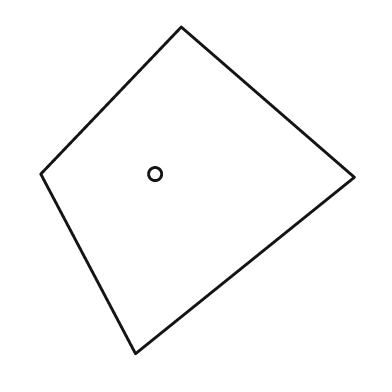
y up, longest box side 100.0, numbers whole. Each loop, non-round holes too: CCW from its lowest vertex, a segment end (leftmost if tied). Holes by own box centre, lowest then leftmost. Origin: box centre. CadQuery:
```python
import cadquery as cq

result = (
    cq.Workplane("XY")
    .moveTo(-19.0, -50.0)
    .lineTo(48.0, 4.0)
    .lineTo(-5.0, 50.0)
    .lineTo(-48.0, 5.0)
    .close()
    .moveTo(-13.0, 5.0)
    .circle(2.0)
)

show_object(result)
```